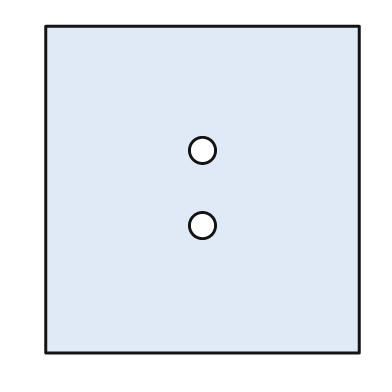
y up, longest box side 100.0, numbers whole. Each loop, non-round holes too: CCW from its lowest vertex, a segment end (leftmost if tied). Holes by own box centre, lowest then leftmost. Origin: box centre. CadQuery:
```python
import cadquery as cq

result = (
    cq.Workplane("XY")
    .moveTo(-48.0, -50.0)
    .lineTo(48.0, -50.0)
    .lineTo(48.0, 50.0)
    .lineTo(-48.0, 50.0)
    .close()
    .moveTo(0.0, -11.0)
    .circle(4.0)
    .moveTo(0.0, 12.0)
    .circle(4.0)
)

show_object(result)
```